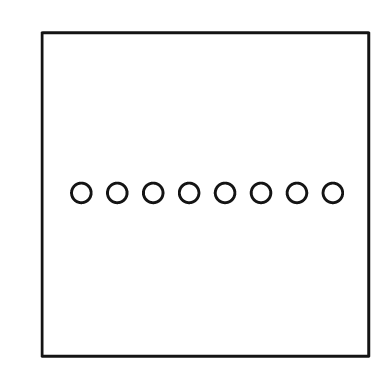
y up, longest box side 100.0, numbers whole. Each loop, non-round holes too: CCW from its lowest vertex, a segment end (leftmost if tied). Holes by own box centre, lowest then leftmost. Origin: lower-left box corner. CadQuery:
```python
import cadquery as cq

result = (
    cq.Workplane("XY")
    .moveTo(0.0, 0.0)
    .lineTo(100.0, 0.0)
    .lineTo(100.0, 99.0)
    .lineTo(0.0, 99.0)
    .close()
    .moveTo(12.0, 50.0)
    .circle(3.0)
    .moveTo(23.0, 50.0)
    .circle(3.0)
    .moveTo(34.0, 50.0)
    .circle(3.0)
    .moveTo(45.0, 50.0)
    .circle(3.0)
    .moveTo(56.0, 50.0)
    .circle(3.0)
    .moveTo(67.0, 50.0)
    .circle(3.0)
    .moveTo(78.0, 50.0)
    .circle(3.0)
    .moveTo(89.0, 50.0)
    .circle(3.0)
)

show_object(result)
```